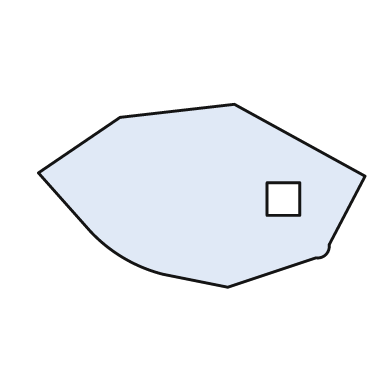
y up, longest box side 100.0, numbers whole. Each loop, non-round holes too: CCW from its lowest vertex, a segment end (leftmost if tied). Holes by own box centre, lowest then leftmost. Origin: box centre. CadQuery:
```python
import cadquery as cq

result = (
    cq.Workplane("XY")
    .moveTo(8.0, -28.0)
    .lineTo(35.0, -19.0)
    .threePointArc((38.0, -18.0), (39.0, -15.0))
    .lineTo(50.0, 6.0)
    .lineTo(10.0, 28.0)
    .lineTo(-25.0, 24.0)
    .lineTo(-50.0, 7.0)
    .lineTo(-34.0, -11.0)
    .threePointArc((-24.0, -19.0), (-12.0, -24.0))
    .close()
    .moveTo(20.0, -6.0)
    .lineTo(30.0, -6.0)
    .lineTo(30.0, 4.0)
    .lineTo(20.0, 4.0)
    .close()
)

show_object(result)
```